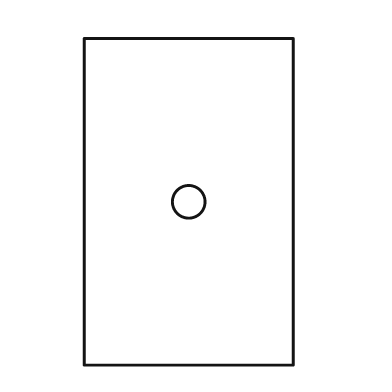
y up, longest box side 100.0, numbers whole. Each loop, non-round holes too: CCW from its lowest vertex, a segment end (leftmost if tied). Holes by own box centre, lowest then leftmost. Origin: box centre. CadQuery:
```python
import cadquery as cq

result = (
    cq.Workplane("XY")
    .moveTo(-32.0, -50.0)
    .lineTo(32.0, -50.0)
    .lineTo(32.0, 50.0)
    .lineTo(-32.0, 50.0)
    .close()
    .moveTo(0.0, 0.0)
    .circle(5.0)
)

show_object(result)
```